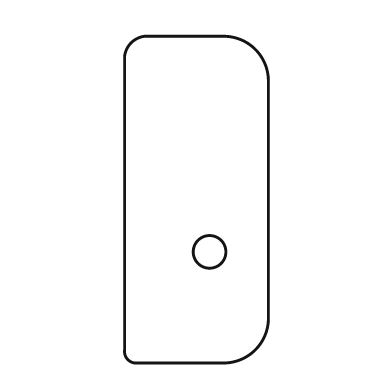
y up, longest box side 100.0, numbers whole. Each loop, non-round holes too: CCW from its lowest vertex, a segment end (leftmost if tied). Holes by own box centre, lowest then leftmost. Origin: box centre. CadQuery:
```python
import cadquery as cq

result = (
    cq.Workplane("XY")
    .moveTo(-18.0, -50.0)
    .lineTo(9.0, -50.0)
    .threePointArc((18.0, -46.0), (22.0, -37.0))
    .lineTo(22.0, 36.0)
    .threePointArc((18.0, 46.0), (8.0, 50.0))
    .lineTo(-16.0, 50.0)
    .threePointArc((-20.0, 48.0), (-22.0, 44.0))
    .lineTo(-22.0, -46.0)
    .threePointArc((-21.0, -49.0), (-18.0, -50.0))
    .close()
    .moveTo(4.0, -16.0)
    .circle(5.0)
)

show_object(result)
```